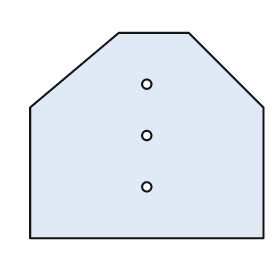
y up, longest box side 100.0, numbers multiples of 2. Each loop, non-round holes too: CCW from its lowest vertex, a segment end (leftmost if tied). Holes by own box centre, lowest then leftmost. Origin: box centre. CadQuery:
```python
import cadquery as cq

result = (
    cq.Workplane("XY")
    .moveTo(-50.0, -44.0)
    .lineTo(50.0, -44.0)
    .lineTo(50.0, 12.0)
    .lineTo(18.0, 44.0)
    .lineTo(-12.0, 44.0)
    .lineTo(-50.0, 12.0)
    .close()
    .moveTo(0.0, -22.0)
    .circle(2.0)
    .moveTo(0.0, 0.0)
    .circle(2.0)
    .moveTo(0.0, 22.0)
    .circle(2.0)
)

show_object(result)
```